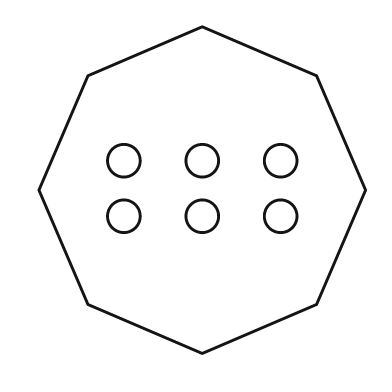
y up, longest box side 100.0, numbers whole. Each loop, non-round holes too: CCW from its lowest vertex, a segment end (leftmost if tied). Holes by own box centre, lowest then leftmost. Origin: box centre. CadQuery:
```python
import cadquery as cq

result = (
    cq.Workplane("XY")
    .moveTo(0.0, -50.0)
    .lineTo(35.0, -35.0)
    .lineTo(50.0, 0.0)
    .lineTo(35.0, 35.0)
    .lineTo(0.0, 50.0)
    .lineTo(-35.0, 35.0)
    .lineTo(-50.0, 0.0)
    .lineTo(-35.0, -35.0)
    .close()
    .moveTo(-24.0, -8.0)
    .circle(5.0)
    .moveTo(0.0, -8.0)
    .circle(5.0)
    .moveTo(24.0, -8.0)
    .circle(5.0)
    .moveTo(-24.0, 9.0)
    .circle(5.0)
    .moveTo(0.0, 9.0)
    .circle(5.0)
    .moveTo(24.0, 9.0)
    .circle(5.0)
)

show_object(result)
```